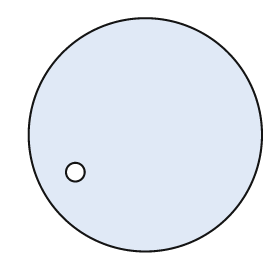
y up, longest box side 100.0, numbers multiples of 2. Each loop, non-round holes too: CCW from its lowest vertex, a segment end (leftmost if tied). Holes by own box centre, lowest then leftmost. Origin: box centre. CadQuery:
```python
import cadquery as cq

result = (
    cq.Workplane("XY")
    .moveTo(0.0, 0.0)
    .circle(50.0)
    .moveTo(-30.0, -16.0)
    .circle(4.0)
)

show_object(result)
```